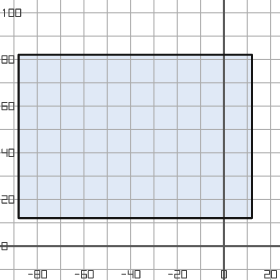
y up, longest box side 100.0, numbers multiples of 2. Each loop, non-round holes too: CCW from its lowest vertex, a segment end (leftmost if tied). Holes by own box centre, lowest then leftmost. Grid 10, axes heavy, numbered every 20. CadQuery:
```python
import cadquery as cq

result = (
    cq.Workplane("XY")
    .moveTo(-88.0, 12.0)
    .lineTo(12.0, 12.0)
    .lineTo(12.0, 82.0)
    .lineTo(-88.0, 82.0)
    .close()
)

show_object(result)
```